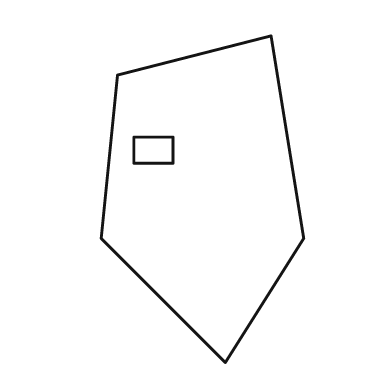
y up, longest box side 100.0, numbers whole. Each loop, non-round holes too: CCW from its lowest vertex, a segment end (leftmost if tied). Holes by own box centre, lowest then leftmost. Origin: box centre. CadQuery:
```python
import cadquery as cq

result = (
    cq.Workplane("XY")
    .moveTo(7.0, -50.0)
    .lineTo(31.0, -12.0)
    .lineTo(21.0, 50.0)
    .lineTo(-26.0, 38.0)
    .lineTo(-31.0, -12.0)
    .close()
    .moveTo(-21.0, 11.0)
    .lineTo(-9.0, 11.0)
    .lineTo(-9.0, 19.0)
    .lineTo(-21.0, 19.0)
    .close()
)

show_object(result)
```